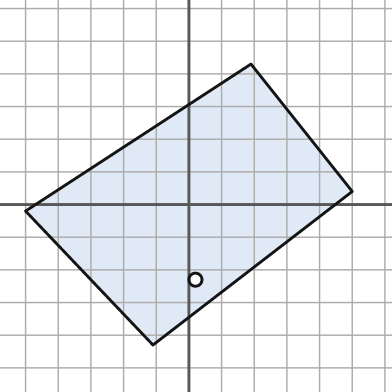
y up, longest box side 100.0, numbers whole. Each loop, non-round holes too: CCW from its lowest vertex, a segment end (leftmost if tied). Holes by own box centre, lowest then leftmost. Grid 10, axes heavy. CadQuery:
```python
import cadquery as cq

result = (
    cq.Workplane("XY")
    .moveTo(-11.0, -43.0)
    .lineTo(50.0, 4.0)
    .lineTo(19.0, 43.0)
    .lineTo(-50.0, -2.0)
    .close()
    .moveTo(2.0, -23.0)
    .circle(2.0)
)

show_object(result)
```